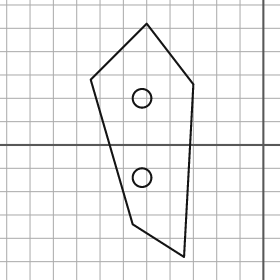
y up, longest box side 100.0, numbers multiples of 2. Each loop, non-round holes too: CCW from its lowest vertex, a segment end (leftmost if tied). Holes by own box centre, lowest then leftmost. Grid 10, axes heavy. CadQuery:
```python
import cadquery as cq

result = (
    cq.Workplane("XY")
    .moveTo(-34.0, -48.0)
    .lineTo(-30.0, 26.0)
    .lineTo(-50.0, 52.0)
    .lineTo(-74.0, 28.0)
    .lineTo(-56.0, -34.0)
    .close()
    .moveTo(-52.0, -14.0)
    .circle(4.0)
    .moveTo(-52.0, 20.0)
    .circle(4.0)
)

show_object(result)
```